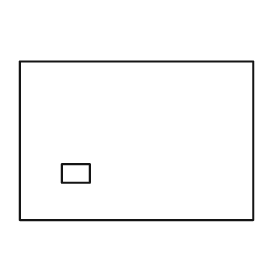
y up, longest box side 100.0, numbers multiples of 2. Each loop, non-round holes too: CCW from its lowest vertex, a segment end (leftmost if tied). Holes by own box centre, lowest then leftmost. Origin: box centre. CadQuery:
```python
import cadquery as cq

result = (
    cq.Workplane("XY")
    .moveTo(-50.0, -34.0)
    .lineTo(50.0, -34.0)
    .lineTo(50.0, 34.0)
    .lineTo(-50.0, 34.0)
    .close()
    .moveTo(-32.0, -18.0)
    .lineTo(-20.0, -18.0)
    .lineTo(-20.0, -10.0)
    .lineTo(-32.0, -10.0)
    .close()
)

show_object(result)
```